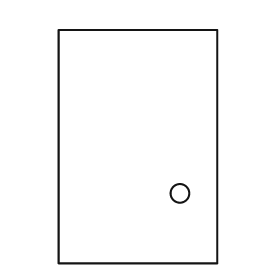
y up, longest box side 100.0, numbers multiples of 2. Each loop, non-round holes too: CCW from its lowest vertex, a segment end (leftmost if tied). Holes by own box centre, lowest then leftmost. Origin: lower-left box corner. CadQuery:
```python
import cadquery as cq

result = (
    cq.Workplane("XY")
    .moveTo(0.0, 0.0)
    .lineTo(68.0, 0.0)
    .lineTo(68.0, 100.0)
    .lineTo(0.0, 100.0)
    .close()
    .moveTo(52.0, 30.0)
    .circle(4.0)
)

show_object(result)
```